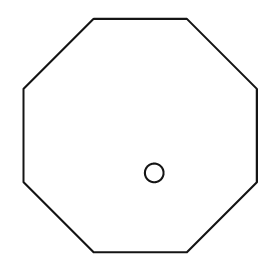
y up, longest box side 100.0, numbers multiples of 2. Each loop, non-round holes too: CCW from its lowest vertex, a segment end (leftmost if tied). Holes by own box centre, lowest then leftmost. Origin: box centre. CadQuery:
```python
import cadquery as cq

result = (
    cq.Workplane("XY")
    .moveTo(-20.0, -50.0)
    .lineTo(20.0, -50.0)
    .lineTo(50.0, -20.0)
    .lineTo(50.0, 20.0)
    .lineTo(20.0, 50.0)
    .lineTo(-20.0, 50.0)
    .lineTo(-50.0, 20.0)
    .lineTo(-50.0, -20.0)
    .close()
    .moveTo(6.0, -16.0)
    .circle(4.0)
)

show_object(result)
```